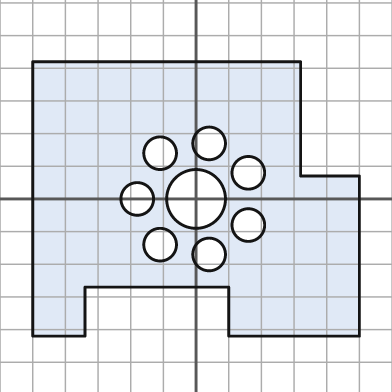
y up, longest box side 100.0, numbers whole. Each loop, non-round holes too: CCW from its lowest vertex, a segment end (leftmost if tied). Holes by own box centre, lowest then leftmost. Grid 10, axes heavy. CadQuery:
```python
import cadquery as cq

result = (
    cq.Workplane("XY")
    .moveTo(-50.0, -42.0)
    .lineTo(-34.0, -42.0)
    .lineTo(-34.0, -27.0)
    .lineTo(10.0, -27.0)
    .lineTo(10.0, -42.0)
    .lineTo(50.0, -42.0)
    .lineTo(50.0, 7.0)
    .lineTo(32.0, 7.0)
    .lineTo(32.0, 42.0)
    .lineTo(-50.0, 42.0)
    .close()
    .moveTo(4.0, -17.0)
    .circle(5.0)
    .moveTo(-11.0, -14.0)
    .circle(5.0)
    .moveTo(16.0, -8.0)
    .circle(5.0)
    .moveTo(-18.0, 0.0)
    .circle(5.0)
    .moveTo(0.0, 0.0)
    .circle(9.0)
    .moveTo(16.0, 8.0)
    .circle(5.0)
    .moveTo(-11.0, 14.0)
    .circle(5.0)
    .moveTo(4.0, 17.0)
    .circle(5.0)
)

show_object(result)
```